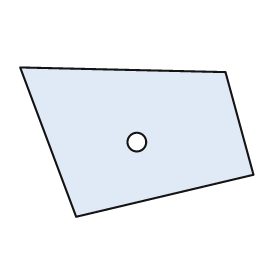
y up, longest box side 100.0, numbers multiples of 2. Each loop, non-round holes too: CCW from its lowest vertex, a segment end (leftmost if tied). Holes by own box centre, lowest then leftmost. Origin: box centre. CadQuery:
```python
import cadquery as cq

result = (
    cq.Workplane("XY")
    .moveTo(-26.0, -32.0)
    .lineTo(50.0, -14.0)
    .lineTo(38.0, 30.0)
    .lineTo(-50.0, 32.0)
    .close()
    .moveTo(0.0, 0.0)
    .circle(4.0)
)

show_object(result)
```